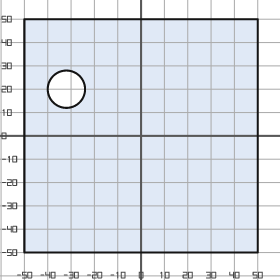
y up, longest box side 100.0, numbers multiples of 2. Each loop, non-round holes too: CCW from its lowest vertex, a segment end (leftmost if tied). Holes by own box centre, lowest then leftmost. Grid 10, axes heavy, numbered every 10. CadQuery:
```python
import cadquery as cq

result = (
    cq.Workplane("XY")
    .moveTo(-50.0, -50.0)
    .lineTo(50.0, -50.0)
    .lineTo(50.0, 50.0)
    .lineTo(-50.0, 50.0)
    .close()
    .moveTo(-32.0, 20.0)
    .circle(8.0)
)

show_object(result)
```